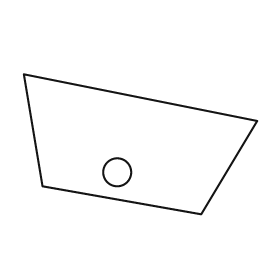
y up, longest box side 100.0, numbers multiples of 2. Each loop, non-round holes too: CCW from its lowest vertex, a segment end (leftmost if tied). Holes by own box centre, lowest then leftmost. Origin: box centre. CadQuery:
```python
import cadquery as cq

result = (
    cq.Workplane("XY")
    .moveTo(26.0, -30.0)
    .lineTo(50.0, 10.0)
    .lineTo(-50.0, 30.0)
    .lineTo(-42.0, -18.0)
    .close()
    .moveTo(-10.0, -12.0)
    .circle(6.0)
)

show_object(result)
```